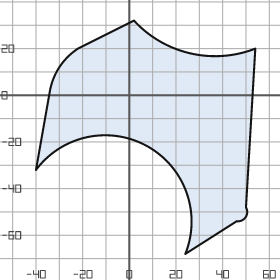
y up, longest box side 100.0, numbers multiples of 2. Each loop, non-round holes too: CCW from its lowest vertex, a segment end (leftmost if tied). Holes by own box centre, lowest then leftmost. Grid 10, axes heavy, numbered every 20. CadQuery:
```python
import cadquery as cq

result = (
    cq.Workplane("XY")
    .moveTo(24.0, -68.0)
    .lineTo(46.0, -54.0)
    .threePointArc((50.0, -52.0), (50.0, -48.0))
    .lineTo(54.0, 20.0)
    .threePointArc((26.0, 18.0), (2.0, 32.0))
    .lineTo(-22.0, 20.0)
    .threePointArc((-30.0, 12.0), (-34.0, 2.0))
    .lineTo(-40.0, -32.0)
    .threePointArc((8.0, -22.0), (24.0, -68.0))
    .close()
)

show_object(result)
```